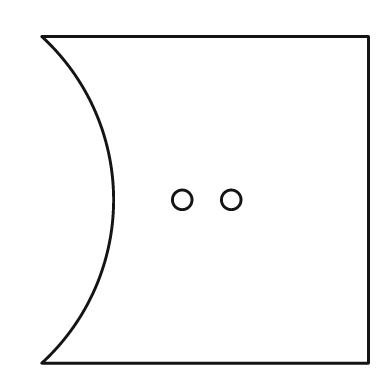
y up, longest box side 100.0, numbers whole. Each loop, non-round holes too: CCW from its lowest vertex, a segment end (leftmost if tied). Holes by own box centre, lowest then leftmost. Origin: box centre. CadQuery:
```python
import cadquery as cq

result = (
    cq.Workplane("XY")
    .moveTo(-50.0, -50.0)
    .lineTo(50.0, -50.0)
    .lineTo(50.0, 50.0)
    .lineTo(-50.0, 50.0)
    .threePointArc((-28.0, 0.0), (-50.0, -50.0))
    .close()
    .moveTo(-7.0, 0.0)
    .circle(3.0)
    .moveTo(8.0, 0.0)
    .circle(3.0)
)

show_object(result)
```